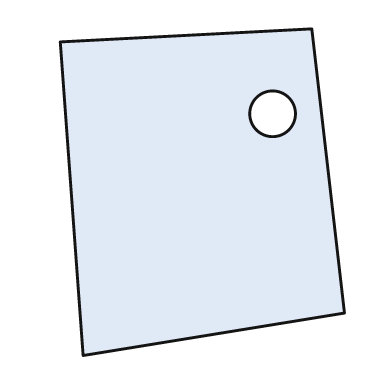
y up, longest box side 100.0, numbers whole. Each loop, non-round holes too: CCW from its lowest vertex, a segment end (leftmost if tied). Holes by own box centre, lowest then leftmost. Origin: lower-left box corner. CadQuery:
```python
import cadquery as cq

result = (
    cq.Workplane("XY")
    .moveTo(7.0, 0.0)
    .lineTo(87.0, 13.0)
    .lineTo(77.0, 100.0)
    .lineTo(0.0, 96.0)
    .close()
    .moveTo(65.0, 74.0)
    .circle(7.0)
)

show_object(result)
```